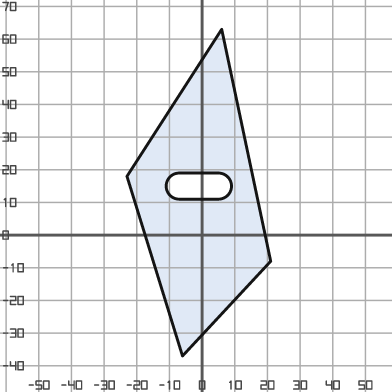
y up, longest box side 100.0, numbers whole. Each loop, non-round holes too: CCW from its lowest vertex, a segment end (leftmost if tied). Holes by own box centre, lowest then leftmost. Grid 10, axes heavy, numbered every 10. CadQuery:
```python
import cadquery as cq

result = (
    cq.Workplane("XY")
    .moveTo(-6.0, -37.0)
    .lineTo(21.0, -8.0)
    .lineTo(6.0, 63.0)
    .lineTo(-23.0, 18.0)
    .close()
    .moveTo(-7.0, 11.0)
    .lineTo(5.0, 11.0)
    .threePointArc((9.0, 15.0), (5.0, 19.0))
    .lineTo(-7.0, 19.0)
    .threePointArc((-11.0, 15.0), (-7.0, 11.0))
    .close()
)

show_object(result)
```